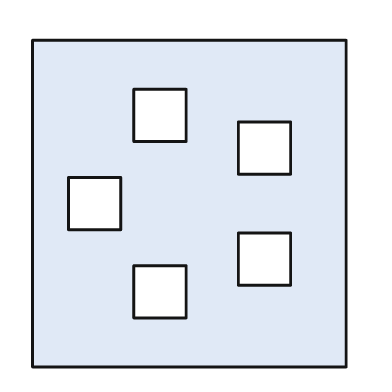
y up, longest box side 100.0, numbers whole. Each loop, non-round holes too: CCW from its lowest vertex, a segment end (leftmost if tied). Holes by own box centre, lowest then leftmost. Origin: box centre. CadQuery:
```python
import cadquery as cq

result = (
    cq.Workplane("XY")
    .moveTo(-48.0, -50.0)
    .lineTo(48.0, -50.0)
    .lineTo(48.0, 50.0)
    .lineTo(-48.0, 50.0)
    .close()
    .moveTo(-17.0, -35.0)
    .lineTo(-1.0, -35.0)
    .lineTo(-1.0, -19.0)
    .lineTo(-17.0, -19.0)
    .close()
    .moveTo(15.0, -25.0)
    .lineTo(31.0, -25.0)
    .lineTo(31.0, -9.0)
    .lineTo(15.0, -9.0)
    .close()
    .moveTo(-37.0, -8.0)
    .lineTo(-21.0, -8.0)
    .lineTo(-21.0, 8.0)
    .lineTo(-37.0, 8.0)
    .close()
    .moveTo(15.0, 9.0)
    .lineTo(31.0, 9.0)
    .lineTo(31.0, 25.0)
    .lineTo(15.0, 25.0)
    .close()
    .moveTo(-17.0, 19.0)
    .lineTo(-1.0, 19.0)
    .lineTo(-1.0, 35.0)
    .lineTo(-17.0, 35.0)
    .close()
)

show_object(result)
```